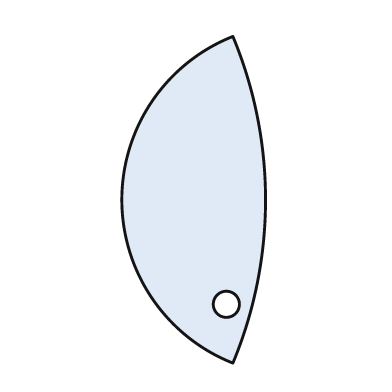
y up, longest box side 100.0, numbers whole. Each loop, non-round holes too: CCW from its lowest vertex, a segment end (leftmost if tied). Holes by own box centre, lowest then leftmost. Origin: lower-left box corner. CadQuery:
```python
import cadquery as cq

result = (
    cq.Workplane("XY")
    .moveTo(34.0, 0.0)
    .threePointArc((44.0, 50.0), (34.0, 100.0))
    .threePointArc((0.0, 50.0), (34.0, 0.0))
    .close()
    .moveTo(32.0, 18.0)
    .circle(4.0)
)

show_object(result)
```